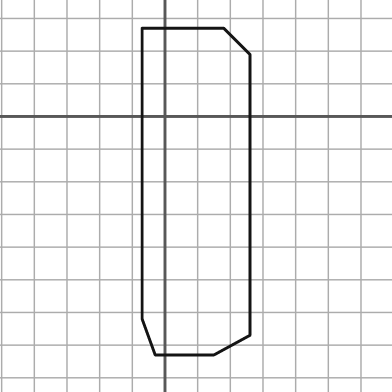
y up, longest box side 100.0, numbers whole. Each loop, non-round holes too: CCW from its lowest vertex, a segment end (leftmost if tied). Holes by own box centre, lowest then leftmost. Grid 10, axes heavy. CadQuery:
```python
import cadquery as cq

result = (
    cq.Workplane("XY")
    .moveTo(-3.0, -73.0)
    .lineTo(15.0, -73.0)
    .lineTo(26.0, -67.0)
    .lineTo(26.0, 19.0)
    .lineTo(18.0, 27.0)
    .lineTo(-7.0, 27.0)
    .lineTo(-7.0, -62.0)
    .close()
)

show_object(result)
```